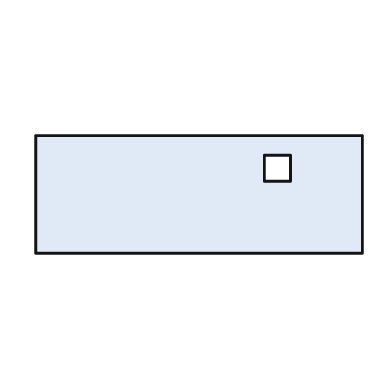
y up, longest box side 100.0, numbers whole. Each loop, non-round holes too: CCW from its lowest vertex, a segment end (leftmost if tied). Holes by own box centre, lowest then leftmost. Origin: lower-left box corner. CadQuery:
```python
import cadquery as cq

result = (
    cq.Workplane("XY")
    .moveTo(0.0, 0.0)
    .lineTo(100.0, 0.0)
    .lineTo(100.0, 36.0)
    .lineTo(0.0, 36.0)
    .close()
    .moveTo(70.0, 22.0)
    .lineTo(78.0, 22.0)
    .lineTo(78.0, 30.0)
    .lineTo(70.0, 30.0)
    .close()
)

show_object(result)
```